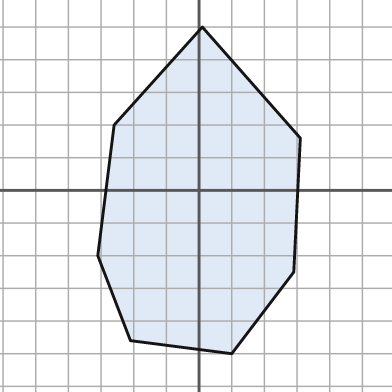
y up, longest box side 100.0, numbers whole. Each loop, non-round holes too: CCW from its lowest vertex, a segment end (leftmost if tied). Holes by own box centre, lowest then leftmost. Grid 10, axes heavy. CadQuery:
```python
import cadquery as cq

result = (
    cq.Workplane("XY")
    .moveTo(10.0, -50.0)
    .lineTo(29.0, -25.0)
    .lineTo(31.0, 16.0)
    .lineTo(1.0, 50.0)
    .lineTo(-26.0, 20.0)
    .lineTo(-31.0, -20.0)
    .lineTo(-21.0, -46.0)
    .close()
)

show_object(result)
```